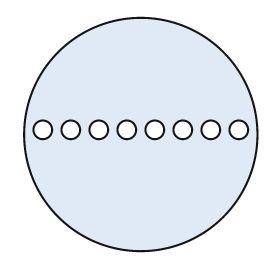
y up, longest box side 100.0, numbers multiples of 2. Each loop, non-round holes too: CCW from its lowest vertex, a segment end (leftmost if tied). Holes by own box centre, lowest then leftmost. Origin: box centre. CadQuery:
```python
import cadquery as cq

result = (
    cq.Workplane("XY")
    .moveTo(0.0, 0.0)
    .circle(50.0)
    .moveTo(-42.0, 2.0)
    .circle(4.0)
    .moveTo(-30.0, 2.0)
    .circle(4.0)
    .moveTo(-18.0, 2.0)
    .circle(4.0)
    .moveTo(-6.0, 2.0)
    .circle(4.0)
    .moveTo(6.0, 2.0)
    .circle(4.0)
    .moveTo(18.0, 2.0)
    .circle(4.0)
    .moveTo(30.0, 2.0)
    .circle(4.0)
    .moveTo(42.0, 2.0)
    .circle(4.0)
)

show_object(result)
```